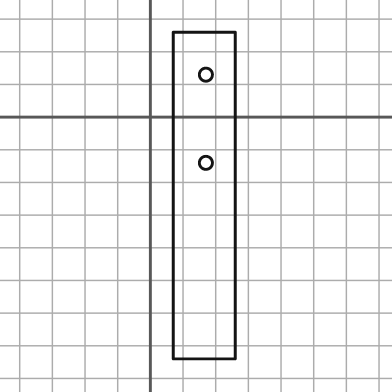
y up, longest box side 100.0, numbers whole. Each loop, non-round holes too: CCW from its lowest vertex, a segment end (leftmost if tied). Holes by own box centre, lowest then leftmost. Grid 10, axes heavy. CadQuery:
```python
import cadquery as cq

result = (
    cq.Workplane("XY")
    .moveTo(7.0, -74.0)
    .lineTo(26.0, -74.0)
    .lineTo(26.0, 26.0)
    .lineTo(7.0, 26.0)
    .close()
    .moveTo(17.0, -14.0)
    .circle(2.0)
    .moveTo(17.0, 13.0)
    .circle(2.0)
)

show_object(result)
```